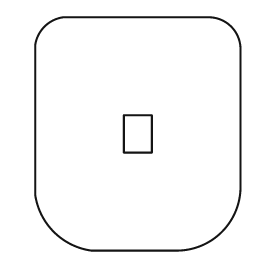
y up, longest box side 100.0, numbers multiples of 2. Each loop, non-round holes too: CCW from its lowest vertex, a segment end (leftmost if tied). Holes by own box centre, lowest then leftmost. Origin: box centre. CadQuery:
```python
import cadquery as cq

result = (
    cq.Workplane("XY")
    .moveTo(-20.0, -50.0)
    .lineTo(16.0, -50.0)
    .threePointArc((36.0, -42.0), (44.0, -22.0))
    .lineTo(44.0, 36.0)
    .threePointArc((40.0, 46.0), (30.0, 50.0))
    .lineTo(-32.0, 50.0)
    .threePointArc((-40.0, 46.0), (-44.0, 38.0))
    .lineTo(-44.0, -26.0)
    .threePointArc((-36.0, -42.0), (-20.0, -50.0))
    .close()
    .moveTo(-6.0, -8.0)
    .lineTo(6.0, -8.0)
    .lineTo(6.0, 8.0)
    .lineTo(-6.0, 8.0)
    .close()
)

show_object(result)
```